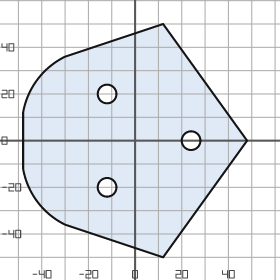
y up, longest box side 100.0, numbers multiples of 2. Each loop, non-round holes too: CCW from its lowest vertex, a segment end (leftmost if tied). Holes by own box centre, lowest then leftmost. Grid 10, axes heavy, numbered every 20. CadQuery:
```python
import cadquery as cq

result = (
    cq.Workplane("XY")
    .moveTo(12.0, -50.0)
    .lineTo(48.0, 0.0)
    .lineTo(12.0, 50.0)
    .lineTo(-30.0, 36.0)
    .threePointArc((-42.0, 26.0), (-48.0, 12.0))
    .lineTo(-48.0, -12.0)
    .threePointArc((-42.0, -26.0), (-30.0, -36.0))
    .close()
    .moveTo(-12.0, -20.0)
    .circle(4.0)
    .moveTo(24.0, 0.0)
    .circle(4.0)
    .moveTo(-12.0, 20.0)
    .circle(4.0)
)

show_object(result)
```